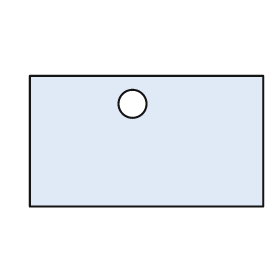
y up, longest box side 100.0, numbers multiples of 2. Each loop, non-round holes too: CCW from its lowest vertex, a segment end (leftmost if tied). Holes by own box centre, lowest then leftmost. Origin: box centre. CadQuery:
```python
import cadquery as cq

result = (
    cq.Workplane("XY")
    .moveTo(-50.0, -28.0)
    .lineTo(50.0, -28.0)
    .lineTo(50.0, 28.0)
    .lineTo(-50.0, 28.0)
    .close()
    .moveTo(-6.0, 16.0)
    .circle(6.0)
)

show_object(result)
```